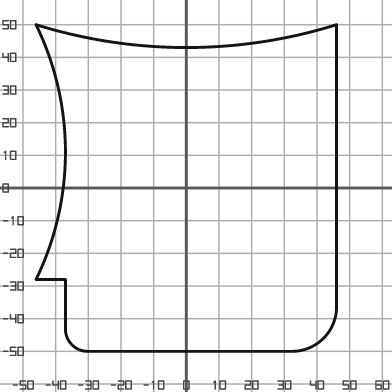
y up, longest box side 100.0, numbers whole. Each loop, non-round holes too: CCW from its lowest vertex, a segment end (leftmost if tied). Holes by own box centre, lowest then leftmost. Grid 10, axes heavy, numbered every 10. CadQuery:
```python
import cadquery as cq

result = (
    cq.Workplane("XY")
    .moveTo(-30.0, -50.0)
    .lineTo(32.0, -50.0)
    .threePointArc((42.0, -46.0), (46.0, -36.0))
    .lineTo(46.0, 50.0)
    .threePointArc((0.0, 43.0), (-46.0, 50.0))
    .threePointArc((-37.0, 11.0), (-46.0, -28.0))
    .lineTo(-37.0, -28.0)
    .lineTo(-37.0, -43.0)
    .threePointArc((-35.0, -48.0), (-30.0, -50.0))
    .close()
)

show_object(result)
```